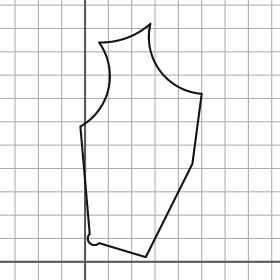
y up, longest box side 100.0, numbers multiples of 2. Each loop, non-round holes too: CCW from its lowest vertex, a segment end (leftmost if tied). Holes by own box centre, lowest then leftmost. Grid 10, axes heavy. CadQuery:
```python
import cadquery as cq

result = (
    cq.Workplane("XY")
    .moveTo(26.0, 2.0)
    .lineTo(46.0, 42.0)
    .lineTo(50.0, 72.0)
    .threePointArc((32.0, 82.0), (28.0, 102.0))
    .threePointArc((18.0, 96.0), (6.0, 94.0))
    .threePointArc((10.0, 74.0), (-2.0, 58.0))
    .lineTo(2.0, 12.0)
    .threePointArc((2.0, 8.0), (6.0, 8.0))
    .close()
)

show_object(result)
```